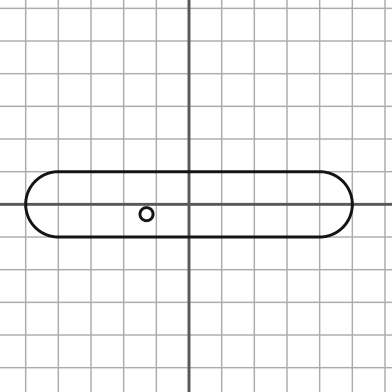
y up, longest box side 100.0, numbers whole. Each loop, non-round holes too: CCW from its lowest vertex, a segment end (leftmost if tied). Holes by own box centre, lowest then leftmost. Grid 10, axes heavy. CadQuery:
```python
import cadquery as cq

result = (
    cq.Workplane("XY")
    .moveTo(-40.0, -10.0)
    .lineTo(40.0, -10.0)
    .threePointArc((50.0, 0.0), (40.0, 10.0))
    .lineTo(-40.0, 10.0)
    .threePointArc((-50.0, 0.0), (-40.0, -10.0))
    .close()
    .moveTo(-13.0, -3.0)
    .circle(2.0)
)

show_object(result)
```